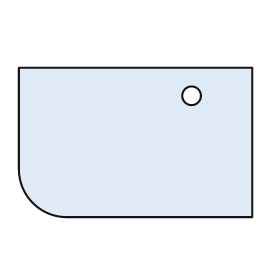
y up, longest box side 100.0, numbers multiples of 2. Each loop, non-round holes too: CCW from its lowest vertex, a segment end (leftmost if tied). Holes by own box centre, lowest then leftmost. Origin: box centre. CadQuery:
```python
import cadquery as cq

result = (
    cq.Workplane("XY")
    .moveTo(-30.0, -32.0)
    .lineTo(50.0, -32.0)
    .lineTo(50.0, 32.0)
    .lineTo(-50.0, 32.0)
    .lineTo(-50.0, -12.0)
    .threePointArc((-44.0, -26.0), (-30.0, -32.0))
    .close()
    .moveTo(24.0, 20.0)
    .circle(4.0)
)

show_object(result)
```